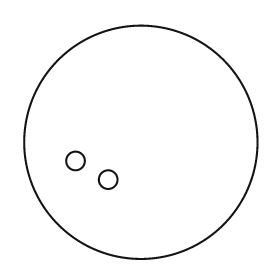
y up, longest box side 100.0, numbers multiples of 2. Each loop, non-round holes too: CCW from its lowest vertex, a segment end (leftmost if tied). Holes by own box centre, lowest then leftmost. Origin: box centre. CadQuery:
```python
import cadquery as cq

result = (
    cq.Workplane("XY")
    .moveTo(0.0, 0.0)
    .circle(50.0)
    .moveTo(-14.0, -16.0)
    .circle(4.0)
    .moveTo(-28.0, -8.0)
    .circle(4.0)
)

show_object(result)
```